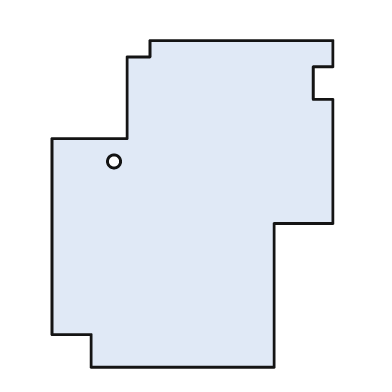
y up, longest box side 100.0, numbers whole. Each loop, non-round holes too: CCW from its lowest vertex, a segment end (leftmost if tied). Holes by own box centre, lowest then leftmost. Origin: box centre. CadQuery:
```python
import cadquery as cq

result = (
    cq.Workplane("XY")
    .moveTo(-31.0, -50.0)
    .lineTo(25.0, -50.0)
    .lineTo(25.0, -6.0)
    .lineTo(43.0, -6.0)
    .lineTo(43.0, 32.0)
    .lineTo(37.0, 32.0)
    .lineTo(37.0, 42.0)
    .lineTo(43.0, 42.0)
    .lineTo(43.0, 50.0)
    .lineTo(-13.0, 50.0)
    .lineTo(-13.0, 45.0)
    .lineTo(-20.0, 45.0)
    .lineTo(-20.0, 20.0)
    .lineTo(-43.0, 20.0)
    .lineTo(-43.0, -40.0)
    .lineTo(-31.0, -40.0)
    .close()
    .moveTo(-24.0, 13.0)
    .circle(2.0)
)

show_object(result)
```